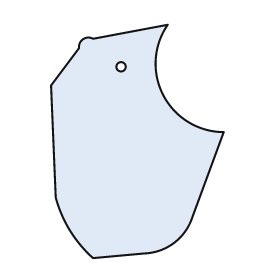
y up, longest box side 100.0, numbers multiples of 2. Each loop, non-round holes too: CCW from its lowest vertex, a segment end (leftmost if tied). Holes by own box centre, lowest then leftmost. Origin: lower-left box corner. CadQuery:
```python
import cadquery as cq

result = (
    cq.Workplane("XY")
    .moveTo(18.0, 0.0)
    .lineTo(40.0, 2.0)
    .threePointArc((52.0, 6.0), (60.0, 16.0))
    .lineTo(74.0, 54.0)
    .threePointArc((48.0, 70.0), (50.0, 100.0))
    .lineTo(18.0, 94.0)
    .threePointArc((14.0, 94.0), (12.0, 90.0))
    .lineTo(0.0, 74.0)
    .lineTo(2.0, 26.0)
    .threePointArc((8.0, 12.0), (18.0, 0.0))
    .close()
    .moveTo(30.0, 82.0)
    .circle(2.0)
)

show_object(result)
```